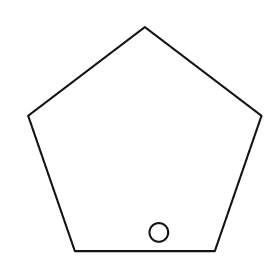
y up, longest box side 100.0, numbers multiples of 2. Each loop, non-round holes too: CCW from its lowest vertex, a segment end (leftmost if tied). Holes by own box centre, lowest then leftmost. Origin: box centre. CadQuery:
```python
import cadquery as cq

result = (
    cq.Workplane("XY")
    .moveTo(-30.0, -48.0)
    .lineTo(30.0, -48.0)
    .lineTo(50.0, 10.0)
    .lineTo(0.0, 48.0)
    .lineTo(-50.0, 10.0)
    .close()
    .moveTo(6.0, -40.0)
    .circle(4.0)
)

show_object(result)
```